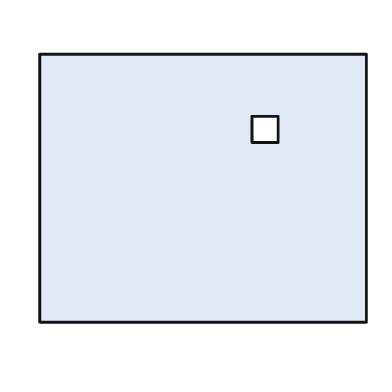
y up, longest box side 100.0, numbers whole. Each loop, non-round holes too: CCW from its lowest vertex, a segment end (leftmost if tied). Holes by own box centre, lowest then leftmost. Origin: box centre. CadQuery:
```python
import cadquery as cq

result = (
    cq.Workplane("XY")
    .moveTo(-50.0, -41.0)
    .lineTo(50.0, -41.0)
    .lineTo(50.0, 41.0)
    .lineTo(-50.0, 41.0)
    .close()
    .moveTo(15.0, 14.0)
    .lineTo(23.0, 14.0)
    .lineTo(23.0, 22.0)
    .lineTo(15.0, 22.0)
    .close()
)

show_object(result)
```